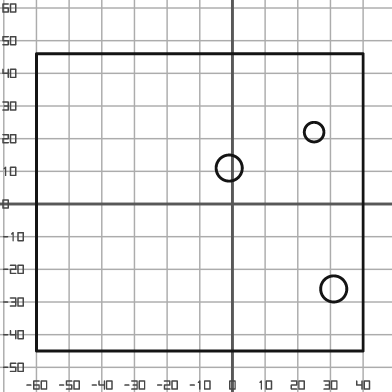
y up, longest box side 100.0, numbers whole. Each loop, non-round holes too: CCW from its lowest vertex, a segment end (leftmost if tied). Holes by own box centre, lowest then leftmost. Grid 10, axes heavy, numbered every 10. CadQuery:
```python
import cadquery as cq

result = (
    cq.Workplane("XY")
    .moveTo(-60.0, -45.0)
    .lineTo(40.0, -45.0)
    .lineTo(40.0, 46.0)
    .lineTo(-60.0, 46.0)
    .close()
    .moveTo(31.0, -26.0)
    .circle(4.0)
    .moveTo(-1.0, 11.0)
    .circle(4.0)
    .moveTo(25.0, 22.0)
    .circle(3.0)
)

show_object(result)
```